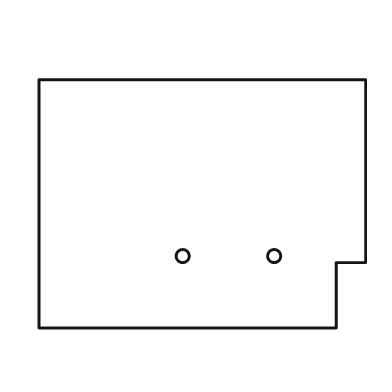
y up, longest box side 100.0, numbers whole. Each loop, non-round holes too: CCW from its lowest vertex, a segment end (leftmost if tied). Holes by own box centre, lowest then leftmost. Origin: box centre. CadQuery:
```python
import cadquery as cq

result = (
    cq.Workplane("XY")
    .moveTo(-50.0, -38.0)
    .lineTo(41.0, -38.0)
    .lineTo(41.0, -18.0)
    .lineTo(50.0, -18.0)
    .lineTo(50.0, 38.0)
    .lineTo(-50.0, 38.0)
    .close()
    .moveTo(-6.0, -16.0)
    .circle(2.0)
    .moveTo(22.0, -16.0)
    .circle(2.0)
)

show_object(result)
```